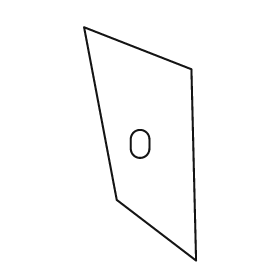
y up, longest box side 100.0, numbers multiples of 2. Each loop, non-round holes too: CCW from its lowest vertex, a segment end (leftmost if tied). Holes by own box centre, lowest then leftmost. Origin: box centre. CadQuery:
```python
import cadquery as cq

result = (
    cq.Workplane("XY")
    .moveTo(24.0, -50.0)
    .lineTo(22.0, 32.0)
    .lineTo(-24.0, 50.0)
    .lineTo(-10.0, -24.0)
    .close()
    .moveTo(-4.0, -2.0)
    .threePointArc((0.0, -6.0), (4.0, -2.0))
    .lineTo(4.0, 2.0)
    .threePointArc((0.0, 6.0), (-4.0, 2.0))
    .close()
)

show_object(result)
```